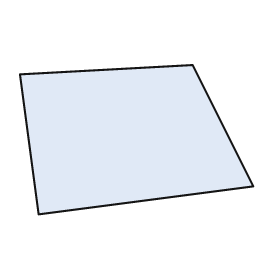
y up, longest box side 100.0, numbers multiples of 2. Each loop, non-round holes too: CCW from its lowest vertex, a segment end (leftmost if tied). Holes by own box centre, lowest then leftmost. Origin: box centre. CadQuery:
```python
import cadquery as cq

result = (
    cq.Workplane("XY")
    .moveTo(-42.0, -32.0)
    .lineTo(50.0, -20.0)
    .lineTo(24.0, 32.0)
    .lineTo(-50.0, 28.0)
    .close()
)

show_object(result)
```